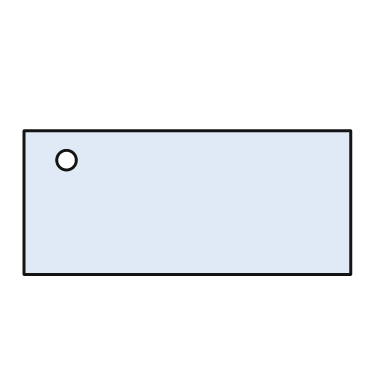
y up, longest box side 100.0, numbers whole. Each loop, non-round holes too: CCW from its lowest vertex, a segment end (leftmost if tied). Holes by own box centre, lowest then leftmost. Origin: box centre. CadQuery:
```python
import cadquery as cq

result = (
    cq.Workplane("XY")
    .moveTo(-50.0, -22.0)
    .lineTo(50.0, -22.0)
    .lineTo(50.0, 22.0)
    .lineTo(-50.0, 22.0)
    .close()
    .moveTo(-37.0, 13.0)
    .circle(3.0)
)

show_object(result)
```